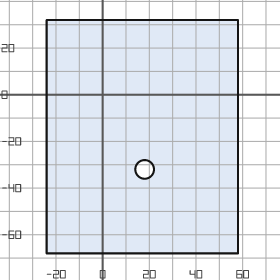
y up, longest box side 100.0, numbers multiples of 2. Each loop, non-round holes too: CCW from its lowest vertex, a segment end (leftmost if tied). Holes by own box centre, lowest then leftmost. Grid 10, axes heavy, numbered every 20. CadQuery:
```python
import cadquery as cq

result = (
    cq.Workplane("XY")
    .moveTo(-24.0, -68.0)
    .lineTo(58.0, -68.0)
    .lineTo(58.0, 32.0)
    .lineTo(-24.0, 32.0)
    .close()
    .moveTo(18.0, -32.0)
    .circle(4.0)
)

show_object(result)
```